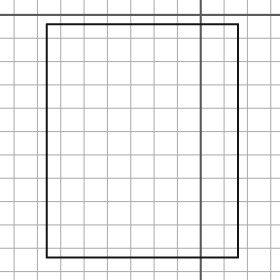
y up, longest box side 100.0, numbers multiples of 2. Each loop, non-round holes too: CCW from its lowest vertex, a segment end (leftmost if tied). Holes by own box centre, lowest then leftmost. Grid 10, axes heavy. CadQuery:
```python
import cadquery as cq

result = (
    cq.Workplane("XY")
    .moveTo(-66.0, -104.0)
    .lineTo(16.0, -104.0)
    .lineTo(16.0, -4.0)
    .lineTo(-66.0, -4.0)
    .close()
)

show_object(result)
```